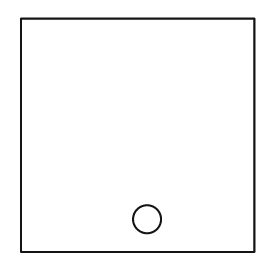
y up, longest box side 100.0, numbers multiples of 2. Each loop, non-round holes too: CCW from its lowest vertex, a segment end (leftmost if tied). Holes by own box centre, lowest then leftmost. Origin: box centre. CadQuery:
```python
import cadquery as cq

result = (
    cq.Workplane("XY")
    .moveTo(-50.0, -50.0)
    .lineTo(50.0, -50.0)
    .lineTo(50.0, 50.0)
    .lineTo(-50.0, 50.0)
    .close()
    .moveTo(4.0, -36.0)
    .circle(6.0)
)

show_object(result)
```